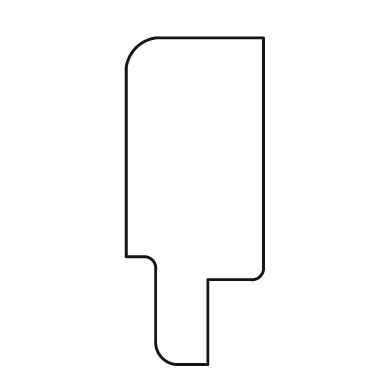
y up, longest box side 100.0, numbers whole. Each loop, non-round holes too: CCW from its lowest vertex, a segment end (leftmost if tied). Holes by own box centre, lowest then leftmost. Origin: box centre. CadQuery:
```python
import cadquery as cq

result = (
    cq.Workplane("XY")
    .moveTo(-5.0, -50.0)
    .lineTo(4.0, -50.0)
    .lineTo(4.0, -24.0)
    .lineTo(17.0, -24.0)
    .threePointArc((20.0, -23.0), (21.0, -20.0))
    .lineTo(21.0, 50.0)
    .lineTo(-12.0, 50.0)
    .threePointArc((-18.0, 47.0), (-21.0, 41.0))
    .lineTo(-21.0, -17.0)
    .lineTo(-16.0, -17.0)
    .threePointArc((-13.0, -18.0), (-12.0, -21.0))
    .lineTo(-12.0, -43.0)
    .threePointArc((-10.0, -48.0), (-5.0, -50.0))
    .close()
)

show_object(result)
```